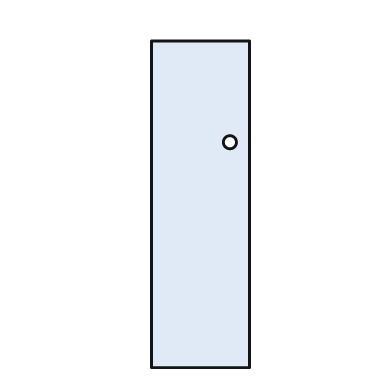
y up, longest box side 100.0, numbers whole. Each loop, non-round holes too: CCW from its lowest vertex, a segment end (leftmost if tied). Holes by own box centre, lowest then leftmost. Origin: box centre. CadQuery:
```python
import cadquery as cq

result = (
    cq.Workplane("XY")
    .moveTo(-15.0, -50.0)
    .lineTo(15.0, -50.0)
    .lineTo(15.0, 50.0)
    .lineTo(-15.0, 50.0)
    .close()
    .moveTo(9.0, 19.0)
    .circle(2.0)
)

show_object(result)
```